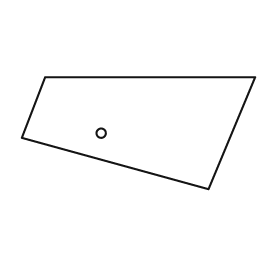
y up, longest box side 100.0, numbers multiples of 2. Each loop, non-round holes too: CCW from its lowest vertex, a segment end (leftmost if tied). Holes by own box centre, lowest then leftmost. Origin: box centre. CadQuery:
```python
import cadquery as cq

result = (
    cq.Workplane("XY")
    .moveTo(30.0, -24.0)
    .lineTo(50.0, 24.0)
    .lineTo(-40.0, 24.0)
    .lineTo(-50.0, -2.0)
    .close()
    .moveTo(-16.0, 0.0)
    .circle(2.0)
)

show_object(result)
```